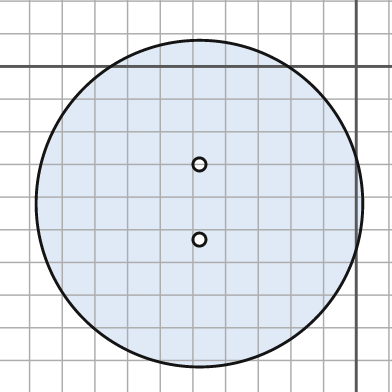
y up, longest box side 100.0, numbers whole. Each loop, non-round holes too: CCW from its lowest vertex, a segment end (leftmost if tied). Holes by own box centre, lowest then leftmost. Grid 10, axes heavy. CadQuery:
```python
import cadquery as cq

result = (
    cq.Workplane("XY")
    .moveTo(-48.0, -42.0)
    .circle(50.0)
    .moveTo(-48.0, -53.0)
    .circle(2.0)
    .moveTo(-48.0, -30.0)
    .circle(2.0)
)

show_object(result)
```